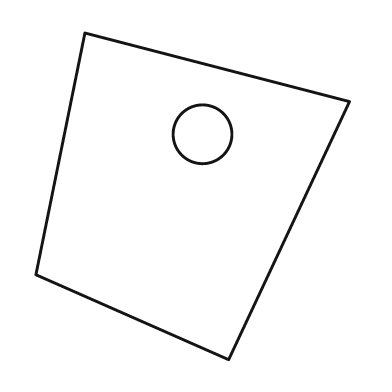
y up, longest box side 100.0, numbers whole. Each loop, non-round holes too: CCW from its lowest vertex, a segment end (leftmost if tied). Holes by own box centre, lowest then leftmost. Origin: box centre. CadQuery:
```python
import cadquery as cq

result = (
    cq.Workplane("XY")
    .moveTo(11.0, -50.0)
    .lineTo(48.0, 29.0)
    .lineTo(-33.0, 50.0)
    .lineTo(-48.0, -24.0)
    .close()
    .moveTo(3.0, 19.0)
    .circle(9.0)
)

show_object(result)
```